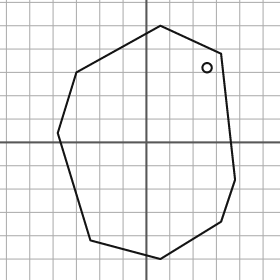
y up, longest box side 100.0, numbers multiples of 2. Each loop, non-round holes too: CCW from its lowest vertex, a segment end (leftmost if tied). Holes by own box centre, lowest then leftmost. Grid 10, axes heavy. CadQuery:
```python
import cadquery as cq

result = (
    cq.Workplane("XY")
    .moveTo(6.0, -50.0)
    .lineTo(32.0, -34.0)
    .lineTo(38.0, -16.0)
    .lineTo(32.0, 38.0)
    .lineTo(6.0, 50.0)
    .lineTo(-30.0, 30.0)
    .lineTo(-38.0, 4.0)
    .lineTo(-24.0, -42.0)
    .close()
    .moveTo(26.0, 32.0)
    .circle(2.0)
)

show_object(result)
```